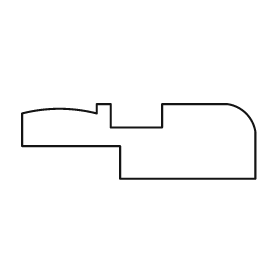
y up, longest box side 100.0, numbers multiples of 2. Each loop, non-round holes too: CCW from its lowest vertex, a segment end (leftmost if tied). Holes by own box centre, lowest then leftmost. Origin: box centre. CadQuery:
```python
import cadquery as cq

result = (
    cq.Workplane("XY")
    .moveTo(-8.0, -16.0)
    .lineTo(50.0, -16.0)
    .lineTo(50.0, 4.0)
    .threePointArc((46.0, 12.0), (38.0, 16.0))
    .lineTo(10.0, 16.0)
    .lineTo(10.0, 6.0)
    .lineTo(-12.0, 6.0)
    .lineTo(-12.0, 16.0)
    .lineTo(-18.0, 16.0)
    .lineTo(-18.0, 12.0)
    .threePointArc((-34.0, 14.0), (-50.0, 12.0))
    .lineTo(-50.0, -2.0)
    .lineTo(-8.0, -2.0)
    .close()
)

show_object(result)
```